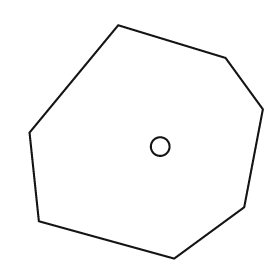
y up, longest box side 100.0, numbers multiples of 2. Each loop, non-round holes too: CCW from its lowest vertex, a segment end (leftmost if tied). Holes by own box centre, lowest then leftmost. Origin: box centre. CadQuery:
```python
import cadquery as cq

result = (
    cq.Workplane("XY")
    .moveTo(12.0, -50.0)
    .lineTo(42.0, -28.0)
    .lineTo(50.0, 14.0)
    .lineTo(34.0, 36.0)
    .lineTo(-12.0, 50.0)
    .lineTo(-50.0, 4.0)
    .lineTo(-46.0, -34.0)
    .close()
    .moveTo(6.0, -2.0)
    .circle(4.0)
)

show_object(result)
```